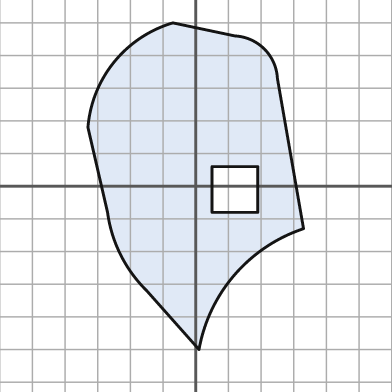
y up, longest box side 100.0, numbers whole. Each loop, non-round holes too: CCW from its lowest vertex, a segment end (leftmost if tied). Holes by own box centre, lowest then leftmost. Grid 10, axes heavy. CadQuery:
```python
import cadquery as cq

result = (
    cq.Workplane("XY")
    .moveTo(1.0, -50.0)
    .threePointArc((12.0, -27.0), (33.0, -13.0))
    .lineTo(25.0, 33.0)
    .threePointArc((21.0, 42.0), (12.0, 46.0))
    .lineTo(-7.0, 50.0)
    .threePointArc((-25.0, 38.0), (-33.0, 18.0))
    .lineTo(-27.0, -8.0)
    .threePointArc((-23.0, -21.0), (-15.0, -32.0))
    .close()
    .moveTo(5.0, -8.0)
    .lineTo(19.0, -8.0)
    .lineTo(19.0, 6.0)
    .lineTo(5.0, 6.0)
    .close()
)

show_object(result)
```